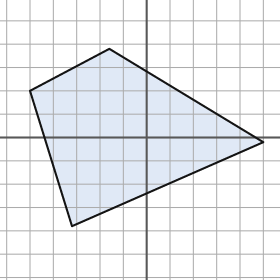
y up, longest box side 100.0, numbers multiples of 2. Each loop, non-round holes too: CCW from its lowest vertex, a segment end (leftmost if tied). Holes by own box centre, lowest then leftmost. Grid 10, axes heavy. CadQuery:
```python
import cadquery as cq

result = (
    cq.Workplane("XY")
    .moveTo(-32.0, -38.0)
    .lineTo(50.0, -2.0)
    .lineTo(-16.0, 38.0)
    .lineTo(-50.0, 20.0)
    .close()
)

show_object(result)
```